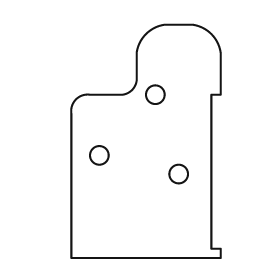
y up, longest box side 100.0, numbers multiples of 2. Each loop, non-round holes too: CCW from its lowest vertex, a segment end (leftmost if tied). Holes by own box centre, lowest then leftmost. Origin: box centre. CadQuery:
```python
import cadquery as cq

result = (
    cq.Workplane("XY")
    .moveTo(-32.0, -50.0)
    .lineTo(32.0, -50.0)
    .lineTo(32.0, -46.0)
    .lineTo(28.0, -46.0)
    .lineTo(28.0, 20.0)
    .lineTo(32.0, 20.0)
    .lineTo(32.0, 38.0)
    .threePointArc((28.0, 46.0), (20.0, 50.0))
    .lineTo(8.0, 50.0)
    .threePointArc((0.0, 46.0), (-4.0, 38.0))
    .lineTo(-4.0, 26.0)
    .threePointArc((-6.0, 22.0), (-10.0, 20.0))
    .lineTo(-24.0, 20.0)
    .threePointArc((-30.0, 18.0), (-32.0, 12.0))
    .close()
    .moveTo(14.0, -14.0)
    .circle(4.0)
    .moveTo(-20.0, -6.0)
    .circle(4.0)
    .moveTo(4.0, 20.0)
    .circle(4.0)
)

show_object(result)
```